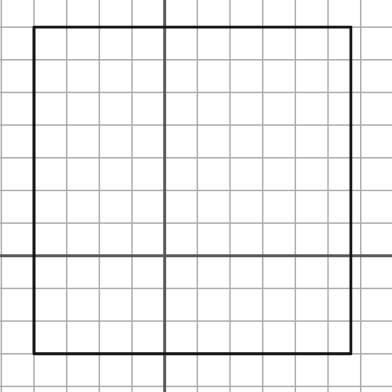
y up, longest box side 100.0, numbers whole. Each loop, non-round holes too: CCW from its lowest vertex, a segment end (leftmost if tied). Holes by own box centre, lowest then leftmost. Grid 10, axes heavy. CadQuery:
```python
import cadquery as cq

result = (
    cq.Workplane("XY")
    .moveTo(-40.0, -30.0)
    .lineTo(57.0, -30.0)
    .lineTo(57.0, 70.0)
    .lineTo(-40.0, 70.0)
    .close()
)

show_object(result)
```